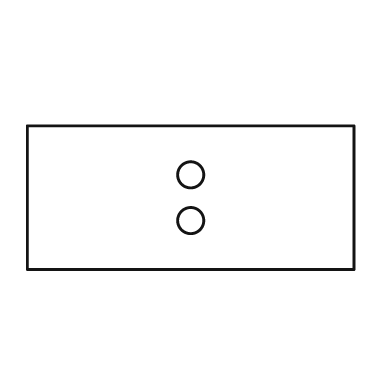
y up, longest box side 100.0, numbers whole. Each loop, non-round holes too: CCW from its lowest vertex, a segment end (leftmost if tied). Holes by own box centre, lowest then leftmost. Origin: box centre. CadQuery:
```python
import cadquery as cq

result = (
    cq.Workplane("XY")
    .moveTo(-50.0, -22.0)
    .lineTo(50.0, -22.0)
    .lineTo(50.0, 22.0)
    .lineTo(-50.0, 22.0)
    .close()
    .moveTo(0.0, -7.0)
    .circle(4.0)
    .moveTo(0.0, 7.0)
    .circle(4.0)
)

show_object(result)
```